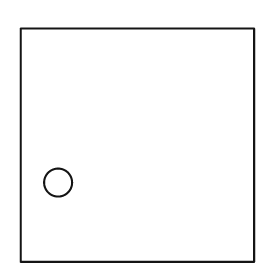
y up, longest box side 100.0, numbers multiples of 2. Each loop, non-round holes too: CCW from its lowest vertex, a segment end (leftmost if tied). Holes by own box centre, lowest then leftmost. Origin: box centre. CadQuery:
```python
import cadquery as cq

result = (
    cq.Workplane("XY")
    .moveTo(-50.0, -50.0)
    .lineTo(50.0, -50.0)
    .lineTo(50.0, 50.0)
    .lineTo(-50.0, 50.0)
    .close()
    .moveTo(-34.0, -16.0)
    .circle(6.0)
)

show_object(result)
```